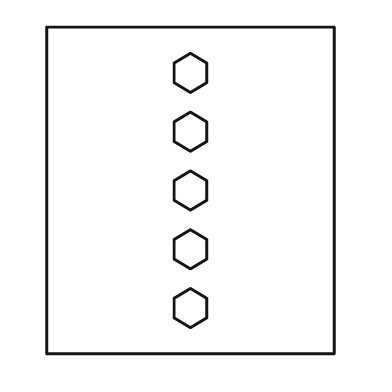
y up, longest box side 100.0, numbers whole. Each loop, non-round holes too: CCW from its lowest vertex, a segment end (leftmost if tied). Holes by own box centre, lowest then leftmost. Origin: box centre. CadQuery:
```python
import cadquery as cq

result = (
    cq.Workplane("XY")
    .moveTo(-44.0, -50.0)
    .lineTo(44.0, -50.0)
    .lineTo(44.0, 50.0)
    .lineTo(-44.0, 50.0)
    .close()
    .moveTo(0.0, -42.0)
    .lineTo(5.0, -39.0)
    .lineTo(5.0, -33.0)
    .lineTo(0.0, -30.0)
    .lineTo(-5.0, -33.0)
    .lineTo(-5.0, -39.0)
    .close()
    .moveTo(0.0, -24.0)
    .lineTo(5.0, -21.0)
    .lineTo(5.0, -15.0)
    .lineTo(0.0, -12.0)
    .lineTo(-5.0, -15.0)
    .lineTo(-5.0, -21.0)
    .close()
    .moveTo(0.0, -6.0)
    .lineTo(5.0, -3.0)
    .lineTo(5.0, 3.0)
    .lineTo(0.0, 6.0)
    .lineTo(-5.0, 3.0)
    .lineTo(-5.0, -3.0)
    .close()
    .moveTo(0.0, 12.0)
    .lineTo(5.0, 15.0)
    .lineTo(5.0, 21.0)
    .lineTo(0.0, 24.0)
    .lineTo(-5.0, 21.0)
    .lineTo(-5.0, 15.0)
    .close()
    .moveTo(0.0, 30.0)
    .lineTo(5.0, 33.0)
    .lineTo(5.0, 39.0)
    .lineTo(0.0, 42.0)
    .lineTo(-5.0, 39.0)
    .lineTo(-5.0, 33.0)
    .close()
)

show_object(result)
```